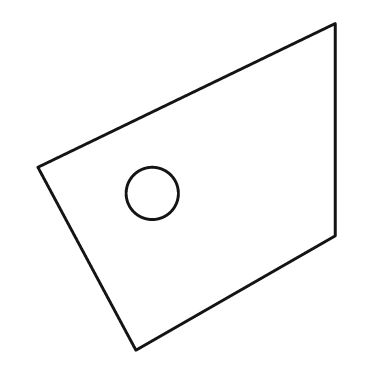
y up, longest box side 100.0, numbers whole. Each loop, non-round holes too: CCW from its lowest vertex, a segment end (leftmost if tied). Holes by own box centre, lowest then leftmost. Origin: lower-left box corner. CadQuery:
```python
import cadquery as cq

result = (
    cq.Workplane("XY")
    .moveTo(30.0, 0.0)
    .lineTo(91.0, 35.0)
    .lineTo(91.0, 100.0)
    .lineTo(0.0, 56.0)
    .close()
    .moveTo(35.0, 48.0)
    .circle(8.0)
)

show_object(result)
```